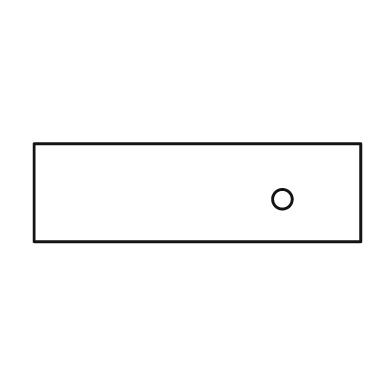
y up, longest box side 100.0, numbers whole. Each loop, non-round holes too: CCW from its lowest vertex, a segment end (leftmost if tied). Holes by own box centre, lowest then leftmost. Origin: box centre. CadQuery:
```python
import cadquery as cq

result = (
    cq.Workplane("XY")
    .moveTo(-50.0, -15.0)
    .lineTo(50.0, -15.0)
    .lineTo(50.0, 15.0)
    .lineTo(-50.0, 15.0)
    .close()
    .moveTo(26.0, -2.0)
    .circle(3.0)
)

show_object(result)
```